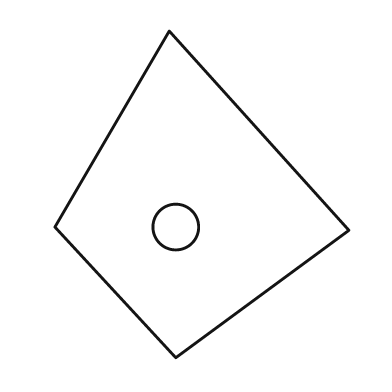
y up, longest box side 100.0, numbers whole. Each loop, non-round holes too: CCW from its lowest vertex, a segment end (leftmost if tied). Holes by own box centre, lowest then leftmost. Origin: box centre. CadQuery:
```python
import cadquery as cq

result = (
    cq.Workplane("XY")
    .moveTo(-8.0, -50.0)
    .lineTo(45.0, -11.0)
    .lineTo(-10.0, 50.0)
    .lineTo(-45.0, -10.0)
    .close()
    .moveTo(-8.0, -10.0)
    .circle(7.0)
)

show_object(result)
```